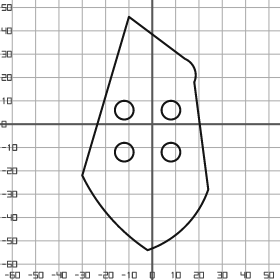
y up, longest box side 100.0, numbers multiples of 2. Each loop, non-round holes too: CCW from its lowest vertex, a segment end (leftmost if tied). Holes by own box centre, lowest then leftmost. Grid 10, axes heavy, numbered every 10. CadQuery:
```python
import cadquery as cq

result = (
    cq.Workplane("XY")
    .moveTo(-2.0, -54.0)
    .threePointArc((14.0, -44.0), (24.0, -28.0))
    .lineTo(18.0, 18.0)
    .threePointArc((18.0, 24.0), (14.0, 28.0))
    .lineTo(-10.0, 46.0)
    .lineTo(-30.0, -22.0)
    .threePointArc((-18.0, -40.0), (-2.0, -54.0))
    .close()
    .moveTo(-12.0, -12.0)
    .circle(4.0)
    .moveTo(8.0, -12.0)
    .circle(4.0)
    .moveTo(-12.0, 6.0)
    .circle(4.0)
    .moveTo(8.0, 6.0)
    .circle(4.0)
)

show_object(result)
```